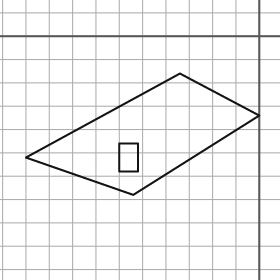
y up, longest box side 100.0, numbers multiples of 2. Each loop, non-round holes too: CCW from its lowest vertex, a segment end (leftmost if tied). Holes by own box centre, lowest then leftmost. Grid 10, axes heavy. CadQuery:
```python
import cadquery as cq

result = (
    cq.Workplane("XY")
    .moveTo(-54.0, -68.0)
    .lineTo(0.0, -34.0)
    .lineTo(-34.0, -16.0)
    .lineTo(-100.0, -52.0)
    .close()
    .moveTo(-60.0, -58.0)
    .lineTo(-52.0, -58.0)
    .lineTo(-52.0, -46.0)
    .lineTo(-60.0, -46.0)
    .close()
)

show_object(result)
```